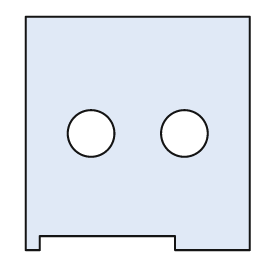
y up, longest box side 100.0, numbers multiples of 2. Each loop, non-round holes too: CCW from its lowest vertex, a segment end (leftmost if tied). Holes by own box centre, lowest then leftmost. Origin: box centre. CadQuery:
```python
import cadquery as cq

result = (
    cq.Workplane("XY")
    .moveTo(-48.0, -50.0)
    .lineTo(-42.0, -50.0)
    .lineTo(-42.0, -44.0)
    .lineTo(16.0, -44.0)
    .lineTo(16.0, -50.0)
    .lineTo(48.0, -50.0)
    .lineTo(48.0, 50.0)
    .lineTo(-48.0, 50.0)
    .close()
    .moveTo(-20.0, 0.0)
    .circle(10.0)
    .moveTo(20.0, 0.0)
    .circle(10.0)
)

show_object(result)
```